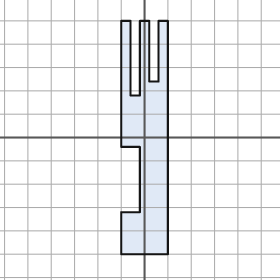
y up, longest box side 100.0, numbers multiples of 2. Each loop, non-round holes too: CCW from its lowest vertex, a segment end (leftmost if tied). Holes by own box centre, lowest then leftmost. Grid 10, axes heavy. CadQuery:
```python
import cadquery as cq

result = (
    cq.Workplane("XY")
    .moveTo(-10.0, -50.0)
    .lineTo(10.0, -50.0)
    .lineTo(10.0, 50.0)
    .lineTo(6.0, 50.0)
    .lineTo(6.0, 24.0)
    .lineTo(2.0, 24.0)
    .lineTo(2.0, 50.0)
    .lineTo(-2.0, 50.0)
    .lineTo(-2.0, 18.0)
    .lineTo(-6.0, 18.0)
    .lineTo(-6.0, 50.0)
    .lineTo(-10.0, 50.0)
    .lineTo(-10.0, -4.0)
    .lineTo(-2.0, -4.0)
    .lineTo(-2.0, -32.0)
    .lineTo(-10.0, -32.0)
    .close()
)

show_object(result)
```